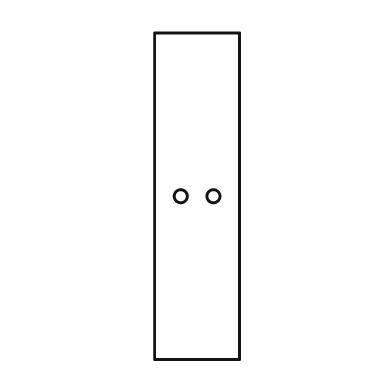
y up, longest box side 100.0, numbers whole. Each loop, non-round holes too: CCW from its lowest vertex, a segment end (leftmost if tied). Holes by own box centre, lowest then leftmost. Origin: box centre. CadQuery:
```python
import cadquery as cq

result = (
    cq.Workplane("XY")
    .moveTo(-13.0, -50.0)
    .lineTo(13.0, -50.0)
    .lineTo(13.0, 50.0)
    .lineTo(-13.0, 50.0)
    .close()
    .moveTo(-5.0, 0.0)
    .circle(2.0)
    .moveTo(5.0, 0.0)
    .circle(2.0)
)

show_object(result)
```